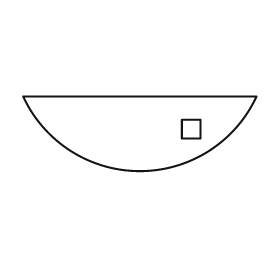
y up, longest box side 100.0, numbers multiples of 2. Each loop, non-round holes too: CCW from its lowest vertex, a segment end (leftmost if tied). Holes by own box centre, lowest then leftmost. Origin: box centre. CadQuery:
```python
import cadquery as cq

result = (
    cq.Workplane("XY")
    .moveTo(-50.0, 16.0)
    .threePointArc((0.0, -16.0), (50.0, 16.0))
    .close()
    .moveTo(18.0, -2.0)
    .lineTo(26.0, -2.0)
    .lineTo(26.0, 6.0)
    .lineTo(18.0, 6.0)
    .close()
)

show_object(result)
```